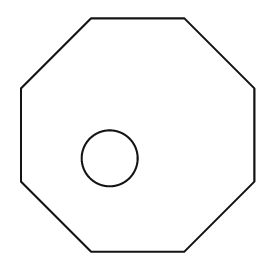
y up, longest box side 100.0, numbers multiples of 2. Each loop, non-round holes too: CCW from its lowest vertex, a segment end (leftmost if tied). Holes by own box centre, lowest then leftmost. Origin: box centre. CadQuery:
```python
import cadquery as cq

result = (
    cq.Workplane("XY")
    .moveTo(-20.0, -50.0)
    .lineTo(20.0, -50.0)
    .lineTo(50.0, -20.0)
    .lineTo(50.0, 20.0)
    .lineTo(20.0, 50.0)
    .lineTo(-20.0, 50.0)
    .lineTo(-50.0, 20.0)
    .lineTo(-50.0, -20.0)
    .close()
    .moveTo(-12.0, -10.0)
    .circle(12.0)
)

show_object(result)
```